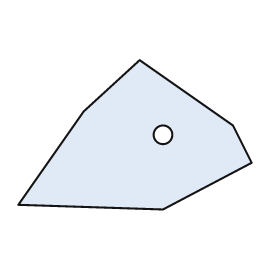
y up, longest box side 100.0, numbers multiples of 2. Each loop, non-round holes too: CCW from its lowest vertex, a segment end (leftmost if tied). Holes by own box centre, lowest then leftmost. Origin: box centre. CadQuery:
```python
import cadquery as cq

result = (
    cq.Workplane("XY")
    .moveTo(12.0, -32.0)
    .lineTo(50.0, -12.0)
    .lineTo(42.0, 4.0)
    .lineTo(2.0, 32.0)
    .lineTo(-22.0, 10.0)
    .lineTo(-50.0, -30.0)
    .close()
    .moveTo(12.0, 0.0)
    .circle(4.0)
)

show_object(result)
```